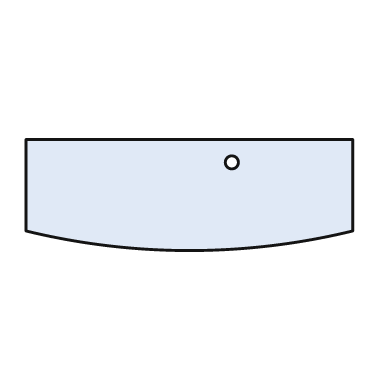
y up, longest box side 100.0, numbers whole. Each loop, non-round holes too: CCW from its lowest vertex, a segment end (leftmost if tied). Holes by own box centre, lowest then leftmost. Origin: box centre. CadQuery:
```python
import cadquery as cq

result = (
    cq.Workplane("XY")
    .moveTo(-50.0, -11.0)
    .threePointArc((0.0, -17.0), (50.0, -11.0))
    .lineTo(50.0, 17.0)
    .lineTo(-50.0, 17.0)
    .close()
    .moveTo(13.0, 10.0)
    .circle(2.0)
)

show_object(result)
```